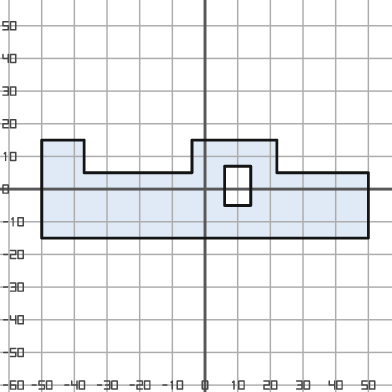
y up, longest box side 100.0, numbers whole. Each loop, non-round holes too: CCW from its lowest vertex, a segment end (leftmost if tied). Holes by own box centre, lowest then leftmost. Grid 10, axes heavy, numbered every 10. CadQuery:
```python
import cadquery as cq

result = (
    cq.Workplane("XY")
    .moveTo(-50.0, -15.0)
    .lineTo(50.0, -15.0)
    .lineTo(50.0, 5.0)
    .lineTo(22.0, 5.0)
    .lineTo(22.0, 15.0)
    .lineTo(-4.0, 15.0)
    .lineTo(-4.0, 5.0)
    .lineTo(-37.0, 5.0)
    .lineTo(-37.0, 15.0)
    .lineTo(-50.0, 15.0)
    .close()
    .moveTo(6.0, -5.0)
    .lineTo(14.0, -5.0)
    .lineTo(14.0, 7.0)
    .lineTo(6.0, 7.0)
    .close()
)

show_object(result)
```